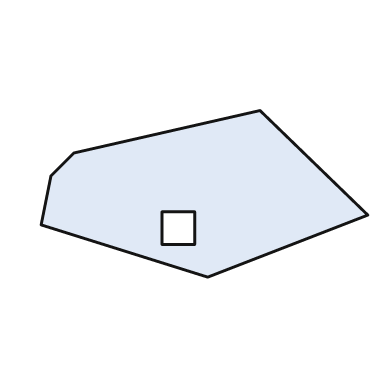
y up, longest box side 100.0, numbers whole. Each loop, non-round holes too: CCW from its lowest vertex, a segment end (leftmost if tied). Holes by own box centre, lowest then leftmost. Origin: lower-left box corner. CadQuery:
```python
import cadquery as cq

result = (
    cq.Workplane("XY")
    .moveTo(51.0, 0.0)
    .lineTo(100.0, 19.0)
    .lineTo(67.0, 51.0)
    .lineTo(10.0, 38.0)
    .lineTo(3.0, 31.0)
    .lineTo(0.0, 16.0)
    .close()
    .moveTo(37.0, 10.0)
    .lineTo(47.0, 10.0)
    .lineTo(47.0, 20.0)
    .lineTo(37.0, 20.0)
    .close()
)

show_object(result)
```